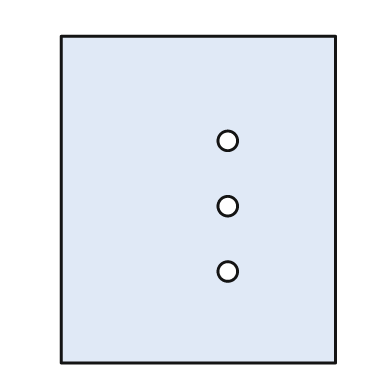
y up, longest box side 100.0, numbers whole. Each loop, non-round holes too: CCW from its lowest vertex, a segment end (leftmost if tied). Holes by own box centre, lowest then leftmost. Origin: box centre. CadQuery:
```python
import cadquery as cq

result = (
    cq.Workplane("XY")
    .moveTo(-42.0, -50.0)
    .lineTo(42.0, -50.0)
    .lineTo(42.0, 50.0)
    .lineTo(-42.0, 50.0)
    .close()
    .moveTo(9.0, -22.0)
    .circle(3.0)
    .moveTo(9.0, -2.0)
    .circle(3.0)
    .moveTo(9.0, 18.0)
    .circle(3.0)
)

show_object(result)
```